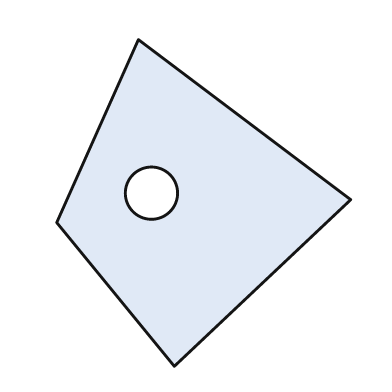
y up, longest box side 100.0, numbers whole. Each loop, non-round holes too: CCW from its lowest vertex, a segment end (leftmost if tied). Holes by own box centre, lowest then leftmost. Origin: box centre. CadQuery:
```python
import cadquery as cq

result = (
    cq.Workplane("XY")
    .moveTo(-9.0, -50.0)
    .lineTo(45.0, 1.0)
    .lineTo(-20.0, 50.0)
    .lineTo(-45.0, -6.0)
    .close()
    .moveTo(-16.0, 3.0)
    .circle(8.0)
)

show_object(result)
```